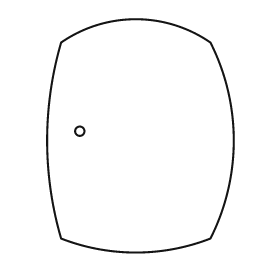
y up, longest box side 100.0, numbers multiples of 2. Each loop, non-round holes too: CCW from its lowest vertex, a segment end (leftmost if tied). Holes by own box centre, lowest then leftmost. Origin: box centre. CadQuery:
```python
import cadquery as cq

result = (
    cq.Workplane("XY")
    .moveTo(-34.0, -44.0)
    .threePointArc((-2.0, -50.0), (30.0, -44.0))
    .threePointArc((40.0, -2.0), (30.0, 40.0))
    .threePointArc((-2.0, 50.0), (-34.0, 40.0))
    .threePointArc((-40.0, -2.0), (-34.0, -44.0))
    .close()
    .moveTo(-26.0, 2.0)
    .circle(2.0)
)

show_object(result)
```